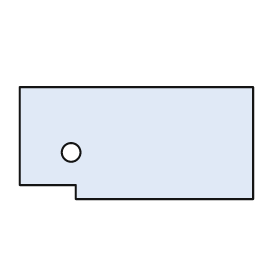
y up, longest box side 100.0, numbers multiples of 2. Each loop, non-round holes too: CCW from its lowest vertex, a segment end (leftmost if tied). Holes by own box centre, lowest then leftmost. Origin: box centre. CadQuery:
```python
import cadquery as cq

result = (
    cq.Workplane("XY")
    .moveTo(-26.0, -24.0)
    .lineTo(50.0, -24.0)
    .lineTo(50.0, 24.0)
    .lineTo(-50.0, 24.0)
    .lineTo(-50.0, -18.0)
    .lineTo(-26.0, -18.0)
    .close()
    .moveTo(-28.0, -4.0)
    .circle(4.0)
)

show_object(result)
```